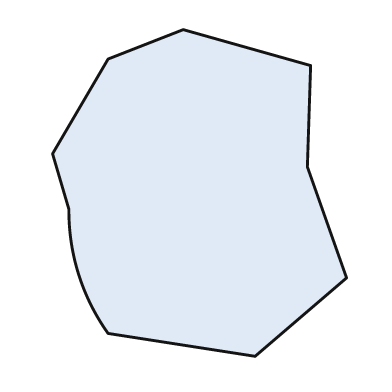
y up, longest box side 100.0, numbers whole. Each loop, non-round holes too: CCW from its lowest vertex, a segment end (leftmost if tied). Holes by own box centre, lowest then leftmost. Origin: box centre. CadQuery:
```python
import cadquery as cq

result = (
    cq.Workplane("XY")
    .moveTo(17.0, -50.0)
    .lineTo(45.0, -26.0)
    .lineTo(33.0, 8.0)
    .lineTo(34.0, 39.0)
    .lineTo(-5.0, 50.0)
    .lineTo(-28.0, 41.0)
    .lineTo(-45.0, 12.0)
    .lineTo(-40.0, -5.0)
    .threePointArc((-37.0, -25.0), (-28.0, -43.0))
    .close()
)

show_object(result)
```